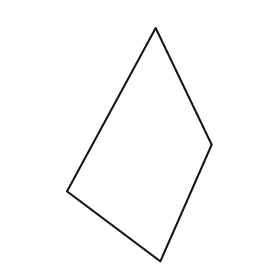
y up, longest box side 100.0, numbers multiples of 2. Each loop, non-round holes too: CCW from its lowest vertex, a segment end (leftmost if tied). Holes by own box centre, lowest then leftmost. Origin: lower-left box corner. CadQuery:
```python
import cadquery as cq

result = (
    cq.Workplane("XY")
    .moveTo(40.0, 0.0)
    .lineTo(62.0, 50.0)
    .lineTo(38.0, 100.0)
    .lineTo(0.0, 30.0)
    .close()
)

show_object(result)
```